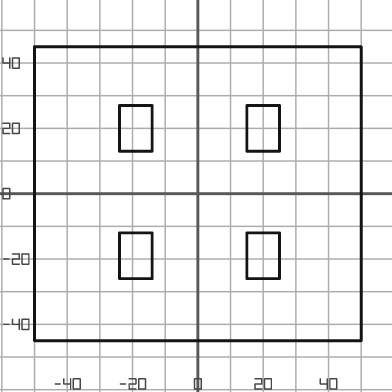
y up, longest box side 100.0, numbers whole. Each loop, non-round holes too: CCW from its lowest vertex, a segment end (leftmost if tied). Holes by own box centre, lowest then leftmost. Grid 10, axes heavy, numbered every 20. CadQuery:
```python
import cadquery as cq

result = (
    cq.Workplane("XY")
    .moveTo(-50.0, -45.0)
    .lineTo(50.0, -45.0)
    .lineTo(50.0, 45.0)
    .lineTo(-50.0, 45.0)
    .close()
    .moveTo(-24.0, -26.0)
    .lineTo(-14.0, -26.0)
    .lineTo(-14.0, -12.0)
    .lineTo(-24.0, -12.0)
    .close()
    .moveTo(15.0, -26.0)
    .lineTo(25.0, -26.0)
    .lineTo(25.0, -12.0)
    .lineTo(15.0, -12.0)
    .close()
    .moveTo(-24.0, 13.0)
    .lineTo(-14.0, 13.0)
    .lineTo(-14.0, 27.0)
    .lineTo(-24.0, 27.0)
    .close()
    .moveTo(15.0, 13.0)
    .lineTo(25.0, 13.0)
    .lineTo(25.0, 27.0)
    .lineTo(15.0, 27.0)
    .close()
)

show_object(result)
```